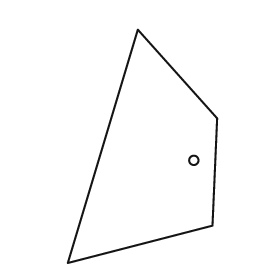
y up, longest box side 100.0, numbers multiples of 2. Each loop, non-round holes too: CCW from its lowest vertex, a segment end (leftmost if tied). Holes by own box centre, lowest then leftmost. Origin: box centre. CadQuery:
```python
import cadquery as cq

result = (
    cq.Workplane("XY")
    .moveTo(-32.0, -50.0)
    .lineTo(30.0, -34.0)
    .lineTo(32.0, 12.0)
    .lineTo(-2.0, 50.0)
    .close()
    .moveTo(22.0, -6.0)
    .circle(2.0)
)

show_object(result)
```